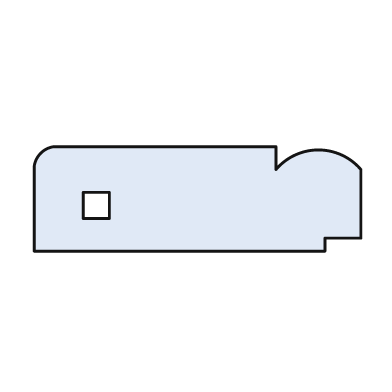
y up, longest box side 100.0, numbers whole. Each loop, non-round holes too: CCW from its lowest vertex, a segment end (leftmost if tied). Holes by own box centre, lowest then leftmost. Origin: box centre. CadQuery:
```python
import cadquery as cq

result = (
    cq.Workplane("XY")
    .moveTo(-50.0, -16.0)
    .lineTo(39.0, -16.0)
    .lineTo(39.0, -12.0)
    .lineTo(50.0, -12.0)
    .lineTo(50.0, 9.0)
    .threePointArc((37.0, 15.0), (24.0, 9.0))
    .lineTo(24.0, 16.0)
    .lineTo(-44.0, 16.0)
    .threePointArc((-48.0, 14.0), (-50.0, 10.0))
    .close()
    .moveTo(-35.0, -6.0)
    .lineTo(-27.0, -6.0)
    .lineTo(-27.0, 2.0)
    .lineTo(-35.0, 2.0)
    .close()
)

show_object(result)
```